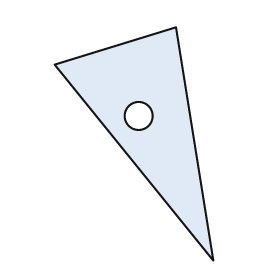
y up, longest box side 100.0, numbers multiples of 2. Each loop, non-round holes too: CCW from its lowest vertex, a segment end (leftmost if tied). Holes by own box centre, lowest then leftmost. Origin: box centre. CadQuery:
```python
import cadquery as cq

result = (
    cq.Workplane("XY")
    .moveTo(34.0, -50.0)
    .lineTo(18.0, 50.0)
    .lineTo(-34.0, 34.0)
    .close()
    .moveTo(2.0, 12.0)
    .circle(6.0)
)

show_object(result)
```